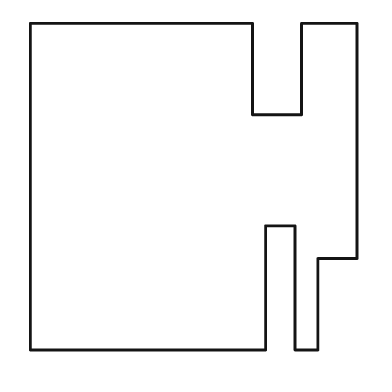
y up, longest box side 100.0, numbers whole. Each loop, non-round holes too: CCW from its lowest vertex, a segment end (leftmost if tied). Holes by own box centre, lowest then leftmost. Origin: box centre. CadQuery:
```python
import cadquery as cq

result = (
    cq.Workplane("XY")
    .moveTo(-50.0, -50.0)
    .lineTo(22.0, -50.0)
    .lineTo(22.0, -12.0)
    .lineTo(31.0, -12.0)
    .lineTo(31.0, -50.0)
    .lineTo(38.0, -50.0)
    .lineTo(38.0, -22.0)
    .lineTo(50.0, -22.0)
    .lineTo(50.0, 50.0)
    .lineTo(33.0, 50.0)
    .lineTo(33.0, 22.0)
    .lineTo(18.0, 22.0)
    .lineTo(18.0, 50.0)
    .lineTo(-50.0, 50.0)
    .close()
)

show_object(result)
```